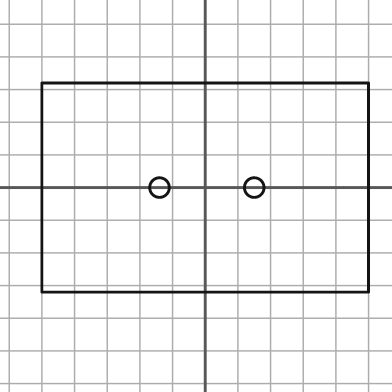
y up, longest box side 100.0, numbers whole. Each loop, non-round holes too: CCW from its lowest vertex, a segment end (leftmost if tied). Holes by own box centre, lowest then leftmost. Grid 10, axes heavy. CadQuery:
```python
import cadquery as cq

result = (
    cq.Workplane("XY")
    .moveTo(-50.0, -32.0)
    .lineTo(50.0, -32.0)
    .lineTo(50.0, 32.0)
    .lineTo(-50.0, 32.0)
    .close()
    .moveTo(-14.0, 0.0)
    .circle(3.0)
    .moveTo(15.0, 0.0)
    .circle(3.0)
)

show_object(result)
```